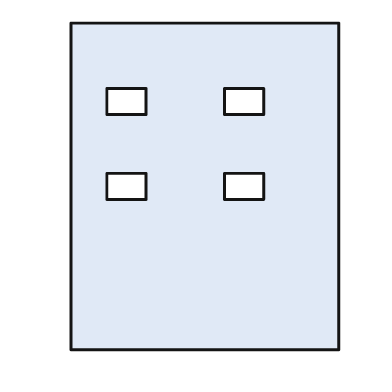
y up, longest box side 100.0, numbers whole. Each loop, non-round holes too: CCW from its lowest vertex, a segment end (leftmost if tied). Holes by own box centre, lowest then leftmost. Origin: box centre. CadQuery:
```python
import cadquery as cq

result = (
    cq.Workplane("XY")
    .moveTo(-41.0, -50.0)
    .lineTo(41.0, -50.0)
    .lineTo(41.0, 50.0)
    .lineTo(-41.0, 50.0)
    .close()
    .moveTo(-30.0, -4.0)
    .lineTo(-18.0, -4.0)
    .lineTo(-18.0, 4.0)
    .lineTo(-30.0, 4.0)
    .close()
    .moveTo(6.0, -4.0)
    .lineTo(18.0, -4.0)
    .lineTo(18.0, 4.0)
    .lineTo(6.0, 4.0)
    .close()
    .moveTo(-30.0, 22.0)
    .lineTo(-18.0, 22.0)
    .lineTo(-18.0, 30.0)
    .lineTo(-30.0, 30.0)
    .close()
    .moveTo(6.0, 22.0)
    .lineTo(18.0, 22.0)
    .lineTo(18.0, 30.0)
    .lineTo(6.0, 30.0)
    .close()
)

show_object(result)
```